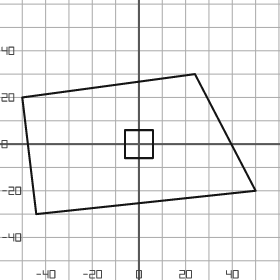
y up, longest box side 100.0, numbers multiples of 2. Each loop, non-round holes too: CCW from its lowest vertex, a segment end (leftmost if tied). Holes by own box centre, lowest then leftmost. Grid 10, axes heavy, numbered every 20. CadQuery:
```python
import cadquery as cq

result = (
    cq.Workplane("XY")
    .moveTo(-44.0, -30.0)
    .lineTo(50.0, -20.0)
    .lineTo(24.0, 30.0)
    .lineTo(-50.0, 20.0)
    .close()
    .moveTo(-6.0, -6.0)
    .lineTo(6.0, -6.0)
    .lineTo(6.0, 6.0)
    .lineTo(-6.0, 6.0)
    .close()
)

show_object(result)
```